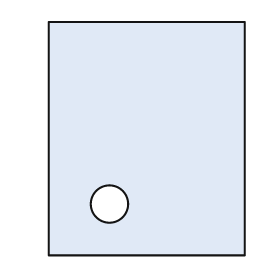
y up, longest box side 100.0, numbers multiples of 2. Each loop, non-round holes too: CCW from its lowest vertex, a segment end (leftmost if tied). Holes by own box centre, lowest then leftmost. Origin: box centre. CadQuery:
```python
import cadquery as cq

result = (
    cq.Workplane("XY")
    .moveTo(-42.0, -50.0)
    .lineTo(42.0, -50.0)
    .lineTo(42.0, 50.0)
    .lineTo(-42.0, 50.0)
    .close()
    .moveTo(-16.0, -28.0)
    .circle(8.0)
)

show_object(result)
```